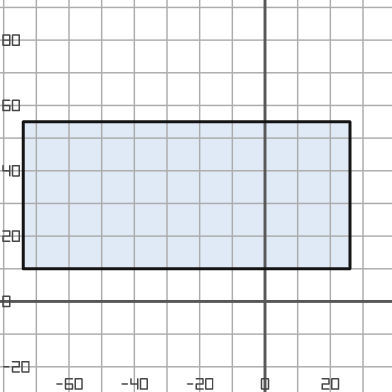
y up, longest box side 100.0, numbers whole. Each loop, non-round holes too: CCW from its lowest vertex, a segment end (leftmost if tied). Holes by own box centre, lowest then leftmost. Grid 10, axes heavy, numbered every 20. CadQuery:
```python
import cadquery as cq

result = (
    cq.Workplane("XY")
    .moveTo(-74.0, 10.0)
    .lineTo(26.0, 10.0)
    .lineTo(26.0, 55.0)
    .lineTo(-74.0, 55.0)
    .close()
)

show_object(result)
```